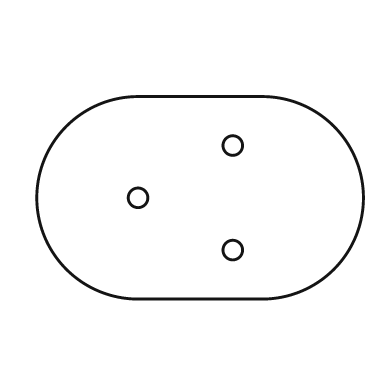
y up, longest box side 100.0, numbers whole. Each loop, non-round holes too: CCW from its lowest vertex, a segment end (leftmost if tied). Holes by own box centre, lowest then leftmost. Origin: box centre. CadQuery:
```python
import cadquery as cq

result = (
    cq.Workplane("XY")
    .moveTo(-19.0, -31.0)
    .lineTo(19.0, -31.0)
    .threePointArc((50.0, 0.0), (19.0, 31.0))
    .lineTo(-19.0, 31.0)
    .threePointArc((-50.0, 0.0), (-19.0, -31.0))
    .close()
    .moveTo(10.0, -16.0)
    .circle(3.0)
    .moveTo(-19.0, 0.0)
    .circle(3.0)
    .moveTo(10.0, 16.0)
    .circle(3.0)
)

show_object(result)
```